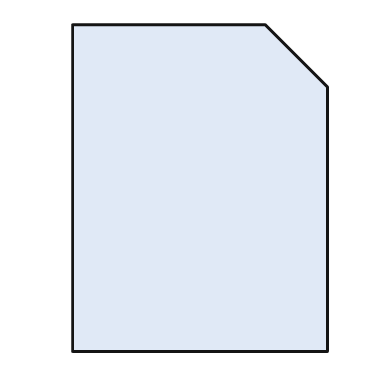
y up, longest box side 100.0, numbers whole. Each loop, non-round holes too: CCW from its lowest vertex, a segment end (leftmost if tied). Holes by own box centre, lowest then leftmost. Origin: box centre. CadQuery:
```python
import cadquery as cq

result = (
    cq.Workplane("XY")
    .moveTo(-39.0, -50.0)
    .lineTo(39.0, -50.0)
    .lineTo(39.0, 31.0)
    .lineTo(20.0, 50.0)
    .lineTo(-39.0, 50.0)
    .close()
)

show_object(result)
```